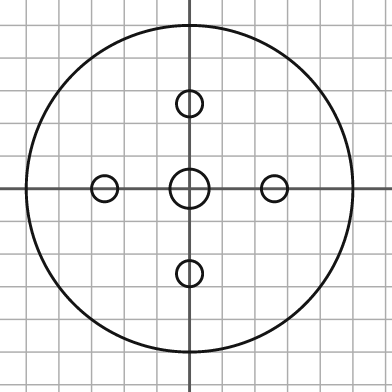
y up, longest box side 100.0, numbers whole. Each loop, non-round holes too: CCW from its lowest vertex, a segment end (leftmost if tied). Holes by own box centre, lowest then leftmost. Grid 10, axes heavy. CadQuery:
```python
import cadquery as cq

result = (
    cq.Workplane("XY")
    .moveTo(0.0, 0.0)
    .circle(50.0)
    .moveTo(0.0, -26.0)
    .circle(4.0)
    .moveTo(-26.0, 0.0)
    .circle(4.0)
    .moveTo(0.0, 0.0)
    .circle(6.0)
    .moveTo(26.0, 0.0)
    .circle(4.0)
    .moveTo(0.0, 26.0)
    .circle(4.0)
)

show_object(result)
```